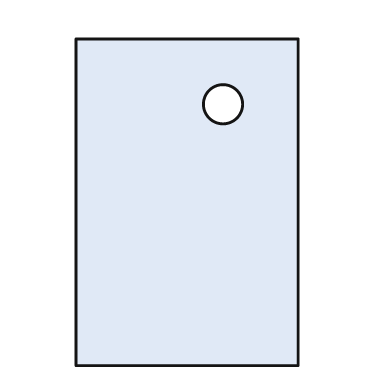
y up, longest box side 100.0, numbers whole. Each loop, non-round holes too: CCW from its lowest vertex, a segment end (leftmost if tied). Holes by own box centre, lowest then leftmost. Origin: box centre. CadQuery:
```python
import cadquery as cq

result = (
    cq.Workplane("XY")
    .moveTo(-34.0, -50.0)
    .lineTo(34.0, -50.0)
    .lineTo(34.0, 50.0)
    .lineTo(-34.0, 50.0)
    .close()
    .moveTo(11.0, 30.0)
    .circle(6.0)
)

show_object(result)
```